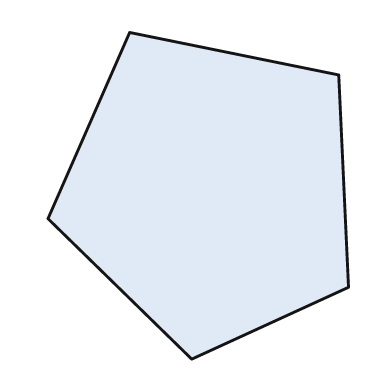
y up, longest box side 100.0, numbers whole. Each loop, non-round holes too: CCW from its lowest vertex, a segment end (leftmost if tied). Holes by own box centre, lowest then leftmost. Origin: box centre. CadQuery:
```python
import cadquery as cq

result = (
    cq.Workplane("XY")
    .moveTo(-2.0, -50.0)
    .lineTo(46.0, -28.0)
    .lineTo(43.0, 37.0)
    .lineTo(-21.0, 50.0)
    .lineTo(-46.0, -7.0)
    .close()
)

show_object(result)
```